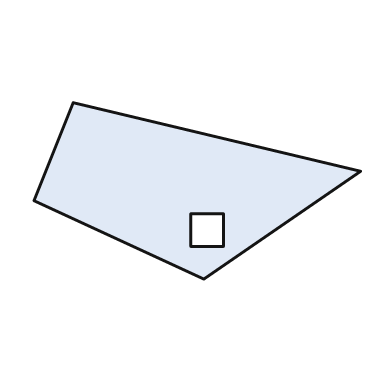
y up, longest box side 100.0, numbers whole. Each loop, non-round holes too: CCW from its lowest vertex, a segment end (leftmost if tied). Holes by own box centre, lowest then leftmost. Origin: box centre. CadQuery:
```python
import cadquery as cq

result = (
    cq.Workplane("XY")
    .moveTo(2.0, -27.0)
    .lineTo(50.0, 6.0)
    .lineTo(-38.0, 27.0)
    .lineTo(-50.0, -3.0)
    .close()
    .moveTo(-2.0, -17.0)
    .lineTo(8.0, -17.0)
    .lineTo(8.0, -7.0)
    .lineTo(-2.0, -7.0)
    .close()
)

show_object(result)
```